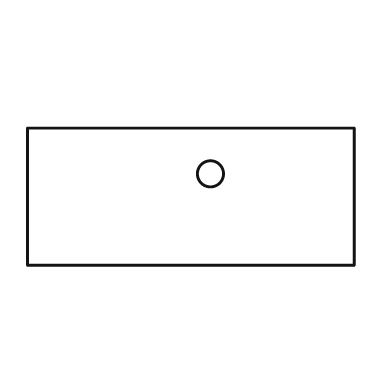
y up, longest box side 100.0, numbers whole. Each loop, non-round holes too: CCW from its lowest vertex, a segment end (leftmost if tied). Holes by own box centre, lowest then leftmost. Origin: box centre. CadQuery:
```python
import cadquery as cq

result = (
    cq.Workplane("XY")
    .moveTo(-50.0, -21.0)
    .lineTo(50.0, -21.0)
    .lineTo(50.0, 21.0)
    .lineTo(-50.0, 21.0)
    .close()
    .moveTo(6.0, 7.0)
    .circle(4.0)
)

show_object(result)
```